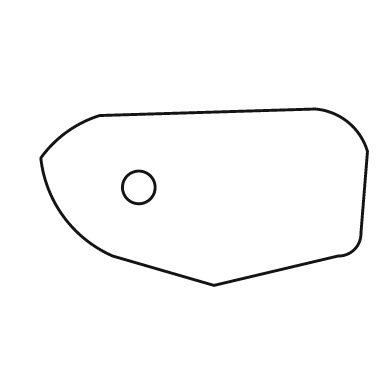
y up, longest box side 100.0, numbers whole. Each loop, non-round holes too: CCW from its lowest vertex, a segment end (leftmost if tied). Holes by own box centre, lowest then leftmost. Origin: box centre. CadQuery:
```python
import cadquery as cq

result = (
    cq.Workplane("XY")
    .moveTo(3.0, -27.0)
    .lineTo(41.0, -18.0)
    .threePointArc((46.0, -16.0), (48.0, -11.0))
    .lineTo(50.0, 14.0)
    .threePointArc((44.0, 23.0), (34.0, 27.0))
    .lineTo(-32.0, 25.0)
    .threePointArc((-42.0, 20.0), (-50.0, 12.0))
    .threePointArc((-43.0, -6.0), (-28.0, -18.0))
    .close()
    .moveTo(-20.0, 3.0)
    .circle(5.0)
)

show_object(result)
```